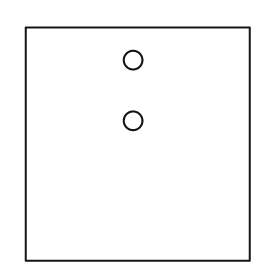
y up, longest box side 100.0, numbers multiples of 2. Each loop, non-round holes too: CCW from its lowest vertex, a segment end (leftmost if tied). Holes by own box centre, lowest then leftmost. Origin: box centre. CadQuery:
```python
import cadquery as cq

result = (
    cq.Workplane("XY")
    .moveTo(-48.0, -50.0)
    .lineTo(48.0, -50.0)
    .lineTo(48.0, 50.0)
    .lineTo(-48.0, 50.0)
    .close()
    .moveTo(-2.0, 10.0)
    .circle(4.0)
    .moveTo(-2.0, 36.0)
    .circle(4.0)
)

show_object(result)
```